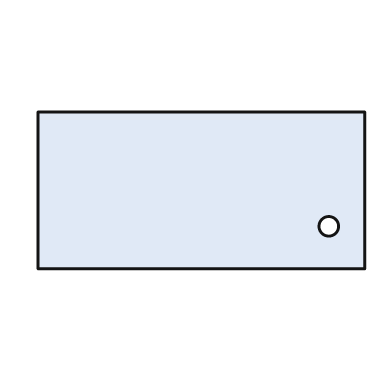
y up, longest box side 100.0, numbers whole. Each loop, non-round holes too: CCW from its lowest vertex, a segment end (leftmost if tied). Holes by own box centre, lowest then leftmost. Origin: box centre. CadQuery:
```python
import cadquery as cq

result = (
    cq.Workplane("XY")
    .moveTo(-50.0, -24.0)
    .lineTo(50.0, -24.0)
    .lineTo(50.0, 24.0)
    .lineTo(-50.0, 24.0)
    .close()
    .moveTo(39.0, -11.0)
    .circle(3.0)
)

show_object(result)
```